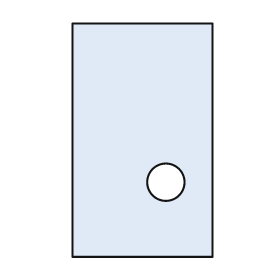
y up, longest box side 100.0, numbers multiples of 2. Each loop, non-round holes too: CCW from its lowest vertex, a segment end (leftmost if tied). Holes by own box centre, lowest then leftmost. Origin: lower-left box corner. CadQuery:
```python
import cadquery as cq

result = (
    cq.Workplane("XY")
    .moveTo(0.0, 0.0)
    .lineTo(60.0, 0.0)
    .lineTo(60.0, 100.0)
    .lineTo(0.0, 100.0)
    .close()
    .moveTo(40.0, 32.0)
    .circle(8.0)
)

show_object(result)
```